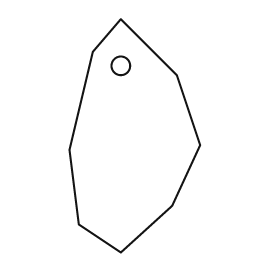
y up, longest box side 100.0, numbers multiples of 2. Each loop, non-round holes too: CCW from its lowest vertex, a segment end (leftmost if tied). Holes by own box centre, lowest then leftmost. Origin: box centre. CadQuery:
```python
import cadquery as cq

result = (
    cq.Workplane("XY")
    .moveTo(-6.0, -50.0)
    .lineTo(16.0, -30.0)
    .lineTo(28.0, -4.0)
    .lineTo(18.0, 26.0)
    .lineTo(-6.0, 50.0)
    .lineTo(-18.0, 36.0)
    .lineTo(-28.0, -6.0)
    .lineTo(-24.0, -38.0)
    .close()
    .moveTo(-6.0, 30.0)
    .circle(4.0)
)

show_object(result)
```